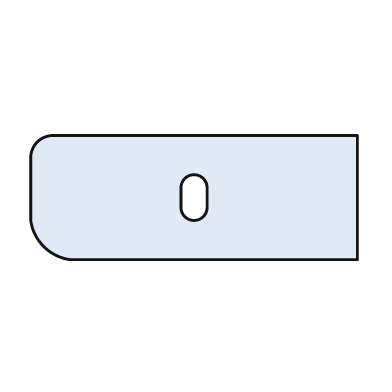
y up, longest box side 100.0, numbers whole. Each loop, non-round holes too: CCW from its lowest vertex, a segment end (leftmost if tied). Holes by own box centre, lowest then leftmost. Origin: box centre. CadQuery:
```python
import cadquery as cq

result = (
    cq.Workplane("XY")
    .moveTo(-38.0, -19.0)
    .lineTo(50.0, -19.0)
    .lineTo(50.0, 19.0)
    .lineTo(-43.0, 19.0)
    .threePointArc((-48.0, 17.0), (-50.0, 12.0))
    .lineTo(-50.0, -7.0)
    .threePointArc((-46.0, -15.0), (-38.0, -19.0))
    .close()
    .moveTo(-4.0, -3.0)
    .threePointArc((0.0, -7.0), (4.0, -3.0))
    .lineTo(4.0, 3.0)
    .threePointArc((0.0, 7.0), (-4.0, 3.0))
    .close()
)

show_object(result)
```